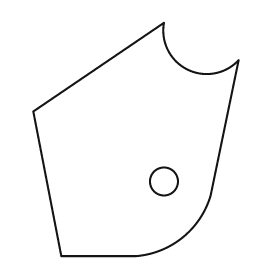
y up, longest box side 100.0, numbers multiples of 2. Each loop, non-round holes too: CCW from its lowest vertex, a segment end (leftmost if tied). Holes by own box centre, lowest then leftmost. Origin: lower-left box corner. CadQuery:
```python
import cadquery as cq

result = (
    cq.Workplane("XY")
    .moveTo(12.0, 0.0)
    .lineTo(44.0, 0.0)
    .threePointArc((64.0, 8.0), (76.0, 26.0))
    .lineTo(88.0, 84.0)
    .threePointArc((66.0, 80.0), (56.0, 100.0))
    .lineTo(0.0, 62.0)
    .close()
    .moveTo(56.0, 32.0)
    .circle(6.0)
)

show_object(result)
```